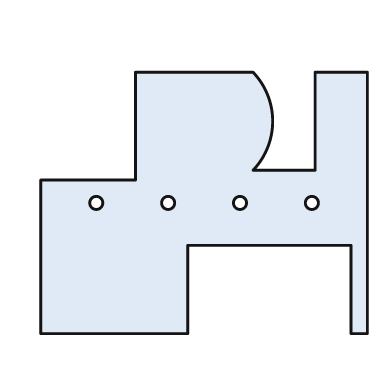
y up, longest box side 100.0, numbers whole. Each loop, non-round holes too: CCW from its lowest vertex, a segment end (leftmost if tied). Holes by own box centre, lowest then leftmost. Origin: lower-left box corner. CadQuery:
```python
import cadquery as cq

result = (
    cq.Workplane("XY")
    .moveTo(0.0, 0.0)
    .lineTo(45.0, 0.0)
    .lineTo(45.0, 27.0)
    .lineTo(95.0, 27.0)
    .lineTo(95.0, 0.0)
    .lineTo(100.0, 0.0)
    .lineTo(100.0, 80.0)
    .lineTo(84.0, 80.0)
    .lineTo(84.0, 50.0)
    .lineTo(65.0, 50.0)
    .threePointArc((71.0, 65.0), (65.0, 80.0))
    .lineTo(29.0, 80.0)
    .lineTo(29.0, 47.0)
    .lineTo(0.0, 47.0)
    .close()
    .moveTo(17.0, 40.0)
    .circle(2.0)
    .moveTo(39.0, 40.0)
    .circle(2.0)
    .moveTo(61.0, 40.0)
    .circle(2.0)
    .moveTo(83.0, 40.0)
    .circle(2.0)
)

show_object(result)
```